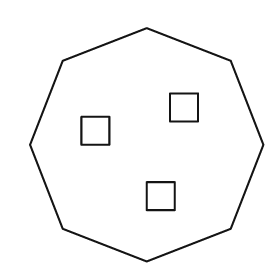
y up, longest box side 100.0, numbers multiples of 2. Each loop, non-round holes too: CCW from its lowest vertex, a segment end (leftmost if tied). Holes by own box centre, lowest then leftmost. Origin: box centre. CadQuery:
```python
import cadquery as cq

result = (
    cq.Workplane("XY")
    .moveTo(0.0, -50.0)
    .lineTo(36.0, -36.0)
    .lineTo(50.0, 0.0)
    .lineTo(36.0, 36.0)
    .lineTo(0.0, 50.0)
    .lineTo(-36.0, 36.0)
    .lineTo(-50.0, 0.0)
    .lineTo(-36.0, -36.0)
    .close()
    .moveTo(0.0, -28.0)
    .lineTo(12.0, -28.0)
    .lineTo(12.0, -16.0)
    .lineTo(0.0, -16.0)
    .close()
    .moveTo(-28.0, 0.0)
    .lineTo(-16.0, 0.0)
    .lineTo(-16.0, 12.0)
    .lineTo(-28.0, 12.0)
    .close()
    .moveTo(10.0, 10.0)
    .lineTo(22.0, 10.0)
    .lineTo(22.0, 22.0)
    .lineTo(10.0, 22.0)
    .close()
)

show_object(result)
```